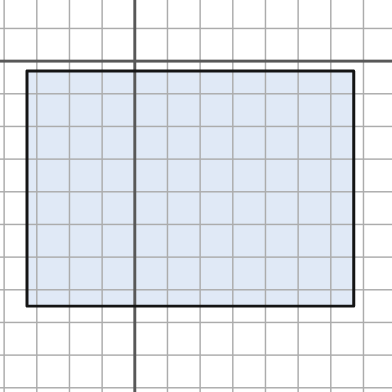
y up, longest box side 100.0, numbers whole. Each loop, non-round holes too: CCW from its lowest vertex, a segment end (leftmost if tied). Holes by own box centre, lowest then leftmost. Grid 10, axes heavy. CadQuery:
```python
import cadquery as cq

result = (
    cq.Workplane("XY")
    .moveTo(-33.0, -75.0)
    .lineTo(67.0, -75.0)
    .lineTo(67.0, -3.0)
    .lineTo(-33.0, -3.0)
    .close()
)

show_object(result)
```